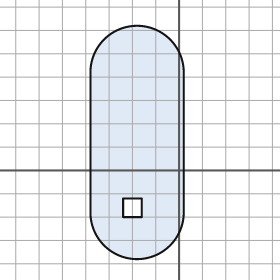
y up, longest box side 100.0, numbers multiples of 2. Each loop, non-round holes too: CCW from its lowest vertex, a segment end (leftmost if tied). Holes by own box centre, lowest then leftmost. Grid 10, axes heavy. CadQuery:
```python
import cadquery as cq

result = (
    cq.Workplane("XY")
    .moveTo(-38.0, -18.0)
    .threePointArc((-18.0, -38.0), (2.0, -18.0))
    .lineTo(2.0, 42.0)
    .threePointArc((-18.0, 62.0), (-38.0, 42.0))
    .close()
    .moveTo(-24.0, -20.0)
    .lineTo(-16.0, -20.0)
    .lineTo(-16.0, -12.0)
    .lineTo(-24.0, -12.0)
    .close()
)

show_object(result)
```